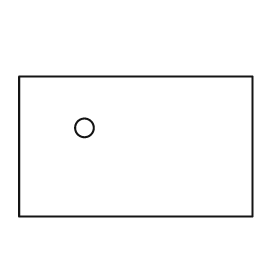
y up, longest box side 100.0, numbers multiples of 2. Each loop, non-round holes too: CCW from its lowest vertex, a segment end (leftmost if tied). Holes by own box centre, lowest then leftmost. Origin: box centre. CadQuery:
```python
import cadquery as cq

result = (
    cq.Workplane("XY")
    .moveTo(-50.0, -30.0)
    .lineTo(50.0, -30.0)
    .lineTo(50.0, 30.0)
    .lineTo(-50.0, 30.0)
    .close()
    .moveTo(-22.0, 8.0)
    .circle(4.0)
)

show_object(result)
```